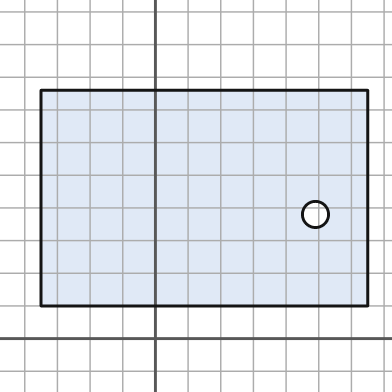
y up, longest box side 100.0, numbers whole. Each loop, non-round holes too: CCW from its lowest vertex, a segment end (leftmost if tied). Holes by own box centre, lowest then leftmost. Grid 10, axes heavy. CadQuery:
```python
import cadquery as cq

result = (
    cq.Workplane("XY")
    .moveTo(-35.0, 10.0)
    .lineTo(65.0, 10.0)
    .lineTo(65.0, 76.0)
    .lineTo(-35.0, 76.0)
    .close()
    .moveTo(49.0, 38.0)
    .circle(4.0)
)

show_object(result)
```